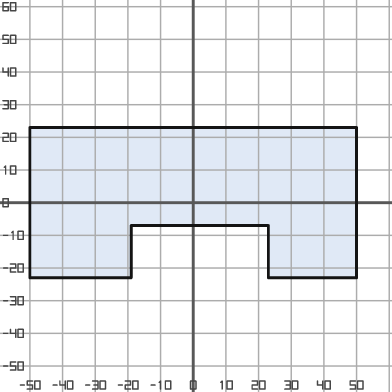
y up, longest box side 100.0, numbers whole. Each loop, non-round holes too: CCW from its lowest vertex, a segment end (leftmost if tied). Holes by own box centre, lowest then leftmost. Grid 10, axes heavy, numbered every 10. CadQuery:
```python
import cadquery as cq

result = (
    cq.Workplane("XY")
    .moveTo(-50.0, -23.0)
    .lineTo(-19.0, -23.0)
    .lineTo(-19.0, -7.0)
    .lineTo(23.0, -7.0)
    .lineTo(23.0, -23.0)
    .lineTo(50.0, -23.0)
    .lineTo(50.0, 23.0)
    .lineTo(-50.0, 23.0)
    .close()
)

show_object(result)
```